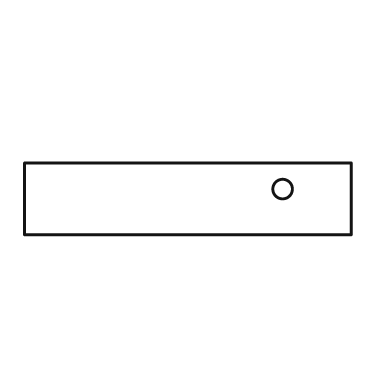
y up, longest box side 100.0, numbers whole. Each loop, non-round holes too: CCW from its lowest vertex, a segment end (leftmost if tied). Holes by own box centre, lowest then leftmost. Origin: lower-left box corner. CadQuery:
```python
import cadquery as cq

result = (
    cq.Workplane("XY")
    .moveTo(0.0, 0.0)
    .lineTo(100.0, 0.0)
    .lineTo(100.0, 22.0)
    .lineTo(0.0, 22.0)
    .close()
    .moveTo(79.0, 14.0)
    .circle(3.0)
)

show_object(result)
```